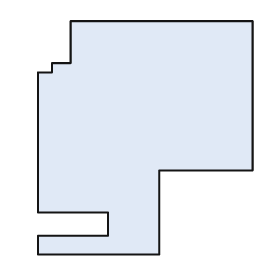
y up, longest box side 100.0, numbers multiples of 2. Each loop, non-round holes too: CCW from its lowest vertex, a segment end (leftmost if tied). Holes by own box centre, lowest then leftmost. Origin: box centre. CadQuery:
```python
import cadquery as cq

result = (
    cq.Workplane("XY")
    .moveTo(-46.0, -50.0)
    .lineTo(6.0, -50.0)
    .lineTo(6.0, -14.0)
    .lineTo(46.0, -14.0)
    .lineTo(46.0, 50.0)
    .lineTo(-32.0, 50.0)
    .lineTo(-32.0, 32.0)
    .lineTo(-40.0, 32.0)
    .lineTo(-40.0, 28.0)
    .lineTo(-46.0, 28.0)
    .lineTo(-46.0, -32.0)
    .lineTo(-16.0, -32.0)
    .lineTo(-16.0, -42.0)
    .lineTo(-46.0, -42.0)
    .close()
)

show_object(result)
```